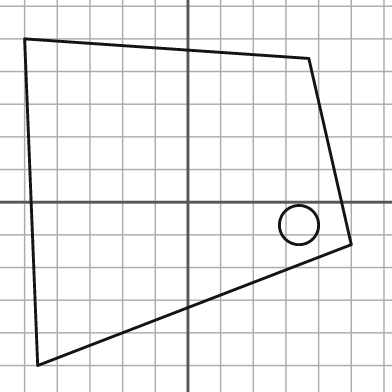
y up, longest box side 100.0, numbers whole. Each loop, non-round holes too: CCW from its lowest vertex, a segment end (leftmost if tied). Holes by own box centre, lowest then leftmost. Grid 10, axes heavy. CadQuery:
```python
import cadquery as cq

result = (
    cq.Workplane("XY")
    .moveTo(-46.0, -50.0)
    .lineTo(50.0, -13.0)
    .lineTo(37.0, 44.0)
    .lineTo(-50.0, 50.0)
    .close()
    .moveTo(34.0, -7.0)
    .circle(6.0)
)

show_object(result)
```